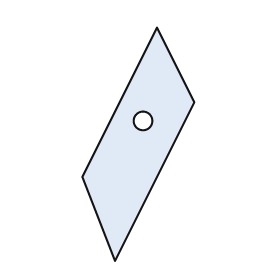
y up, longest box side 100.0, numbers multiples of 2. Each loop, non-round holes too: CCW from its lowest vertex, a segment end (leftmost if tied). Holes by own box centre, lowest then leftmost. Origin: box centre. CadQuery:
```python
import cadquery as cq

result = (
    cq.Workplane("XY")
    .moveTo(-10.0, -50.0)
    .lineTo(24.0, 18.0)
    .lineTo(8.0, 50.0)
    .lineTo(-24.0, -14.0)
    .close()
    .moveTo(2.0, 10.0)
    .circle(4.0)
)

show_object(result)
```